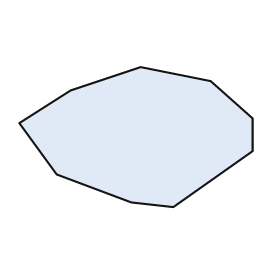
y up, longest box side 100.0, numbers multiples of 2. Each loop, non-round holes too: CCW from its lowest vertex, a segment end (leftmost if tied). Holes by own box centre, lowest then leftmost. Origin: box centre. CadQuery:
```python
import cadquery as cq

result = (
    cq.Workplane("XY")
    .moveTo(16.0, -30.0)
    .lineTo(50.0, -6.0)
    .lineTo(50.0, 8.0)
    .lineTo(32.0, 24.0)
    .lineTo(2.0, 30.0)
    .lineTo(-28.0, 20.0)
    .lineTo(-50.0, 6.0)
    .lineTo(-34.0, -16.0)
    .lineTo(-2.0, -28.0)
    .close()
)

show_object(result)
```